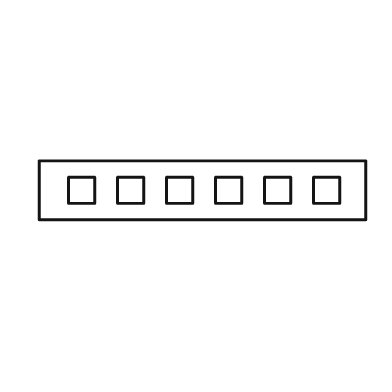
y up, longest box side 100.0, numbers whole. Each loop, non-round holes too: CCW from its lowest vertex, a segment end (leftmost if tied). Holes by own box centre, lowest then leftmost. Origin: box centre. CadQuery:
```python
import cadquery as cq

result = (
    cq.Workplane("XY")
    .moveTo(-50.0, -9.0)
    .lineTo(50.0, -9.0)
    .lineTo(50.0, 9.0)
    .lineTo(-50.0, 9.0)
    .close()
    .moveTo(-41.0, -4.0)
    .lineTo(-33.0, -4.0)
    .lineTo(-33.0, 4.0)
    .lineTo(-41.0, 4.0)
    .close()
    .moveTo(-26.0, -4.0)
    .lineTo(-18.0, -4.0)
    .lineTo(-18.0, 4.0)
    .lineTo(-26.0, 4.0)
    .close()
    .moveTo(-11.0, -4.0)
    .lineTo(-3.0, -4.0)
    .lineTo(-3.0, 4.0)
    .lineTo(-11.0, 4.0)
    .close()
    .moveTo(4.0, -4.0)
    .lineTo(12.0, -4.0)
    .lineTo(12.0, 4.0)
    .lineTo(4.0, 4.0)
    .close()
    .moveTo(19.0, -4.0)
    .lineTo(27.0, -4.0)
    .lineTo(27.0, 4.0)
    .lineTo(19.0, 4.0)
    .close()
    .moveTo(34.0, -4.0)
    .lineTo(42.0, -4.0)
    .lineTo(42.0, 4.0)
    .lineTo(34.0, 4.0)
    .close()
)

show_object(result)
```